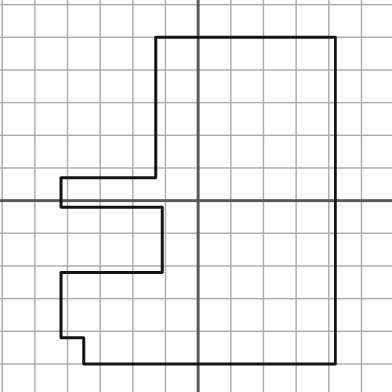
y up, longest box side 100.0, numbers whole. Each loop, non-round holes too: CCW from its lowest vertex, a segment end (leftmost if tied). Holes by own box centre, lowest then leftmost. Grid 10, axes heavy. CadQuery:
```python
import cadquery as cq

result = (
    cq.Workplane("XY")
    .moveTo(-35.0, -50.0)
    .lineTo(42.0, -50.0)
    .lineTo(42.0, 50.0)
    .lineTo(-13.0, 50.0)
    .lineTo(-13.0, 7.0)
    .lineTo(-42.0, 7.0)
    .lineTo(-42.0, -2.0)
    .lineTo(-11.0, -2.0)
    .lineTo(-11.0, -22.0)
    .lineTo(-42.0, -22.0)
    .lineTo(-42.0, -42.0)
    .lineTo(-35.0, -42.0)
    .close()
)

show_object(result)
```